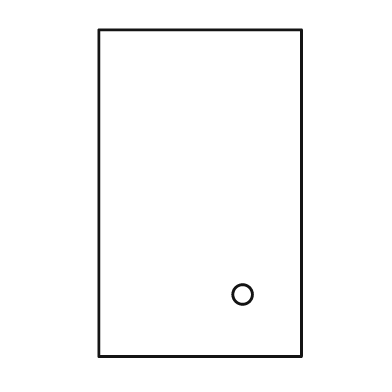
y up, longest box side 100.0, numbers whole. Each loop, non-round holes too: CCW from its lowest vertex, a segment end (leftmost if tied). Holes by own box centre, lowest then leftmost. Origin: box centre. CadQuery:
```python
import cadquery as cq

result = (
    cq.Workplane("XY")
    .moveTo(-31.0, -50.0)
    .lineTo(31.0, -50.0)
    .lineTo(31.0, 50.0)
    .lineTo(-31.0, 50.0)
    .close()
    .moveTo(13.0, -31.0)
    .circle(3.0)
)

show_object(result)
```